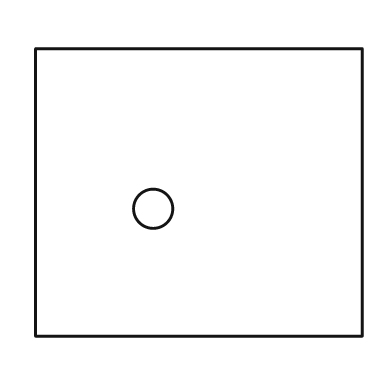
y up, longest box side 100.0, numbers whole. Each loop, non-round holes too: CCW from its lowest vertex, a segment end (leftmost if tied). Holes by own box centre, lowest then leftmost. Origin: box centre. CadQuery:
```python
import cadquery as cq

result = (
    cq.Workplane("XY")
    .moveTo(-50.0, -44.0)
    .lineTo(50.0, -44.0)
    .lineTo(50.0, 44.0)
    .lineTo(-50.0, 44.0)
    .close()
    .moveTo(-14.0, -5.0)
    .circle(6.0)
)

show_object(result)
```